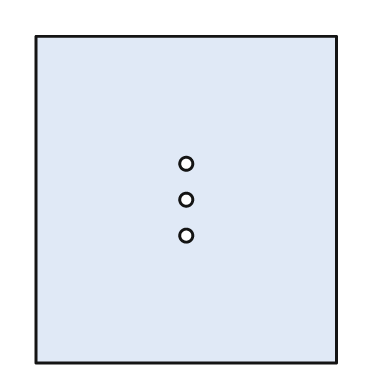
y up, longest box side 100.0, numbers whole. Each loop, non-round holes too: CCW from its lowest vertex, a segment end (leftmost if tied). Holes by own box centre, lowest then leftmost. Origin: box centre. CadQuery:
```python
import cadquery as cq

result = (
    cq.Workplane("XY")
    .moveTo(-46.0, -50.0)
    .lineTo(46.0, -50.0)
    .lineTo(46.0, 50.0)
    .lineTo(-46.0, 50.0)
    .close()
    .moveTo(0.0, -11.0)
    .circle(2.0)
    .moveTo(0.0, 0.0)
    .circle(2.0)
    .moveTo(0.0, 11.0)
    .circle(2.0)
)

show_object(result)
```